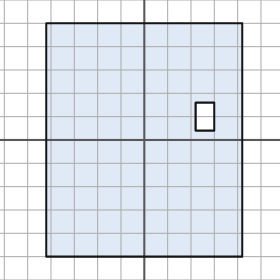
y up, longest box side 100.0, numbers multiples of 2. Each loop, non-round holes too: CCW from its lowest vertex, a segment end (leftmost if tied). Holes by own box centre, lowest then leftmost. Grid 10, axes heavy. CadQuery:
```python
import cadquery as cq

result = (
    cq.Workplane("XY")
    .moveTo(-42.0, -50.0)
    .lineTo(42.0, -50.0)
    .lineTo(42.0, 50.0)
    .lineTo(-42.0, 50.0)
    .close()
    .moveTo(22.0, 4.0)
    .lineTo(30.0, 4.0)
    .lineTo(30.0, 16.0)
    .lineTo(22.0, 16.0)
    .close()
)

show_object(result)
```